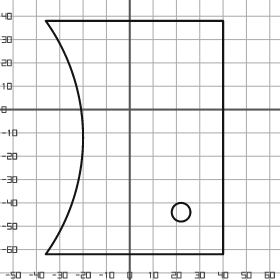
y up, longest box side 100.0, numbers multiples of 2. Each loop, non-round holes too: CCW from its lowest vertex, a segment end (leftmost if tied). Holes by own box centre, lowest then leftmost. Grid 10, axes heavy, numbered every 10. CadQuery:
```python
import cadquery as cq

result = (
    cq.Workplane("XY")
    .moveTo(-36.0, -62.0)
    .lineTo(40.0, -62.0)
    .lineTo(40.0, 38.0)
    .lineTo(-36.0, 38.0)
    .threePointArc((-20.0, -12.0), (-36.0, -62.0))
    .close()
    .moveTo(22.0, -44.0)
    .circle(4.0)
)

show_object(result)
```